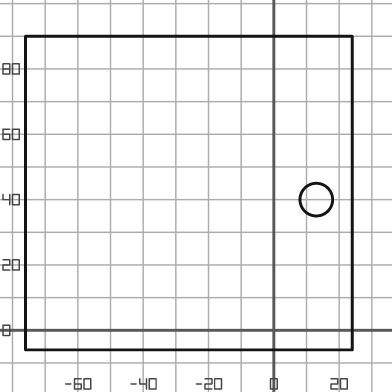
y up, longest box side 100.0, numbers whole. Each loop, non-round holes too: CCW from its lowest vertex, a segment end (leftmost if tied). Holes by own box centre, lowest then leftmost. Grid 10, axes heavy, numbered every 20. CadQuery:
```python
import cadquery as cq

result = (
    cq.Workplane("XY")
    .moveTo(-76.0, -6.0)
    .lineTo(24.0, -6.0)
    .lineTo(24.0, 90.0)
    .lineTo(-76.0, 90.0)
    .close()
    .moveTo(13.0, 40.0)
    .circle(5.0)
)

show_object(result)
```